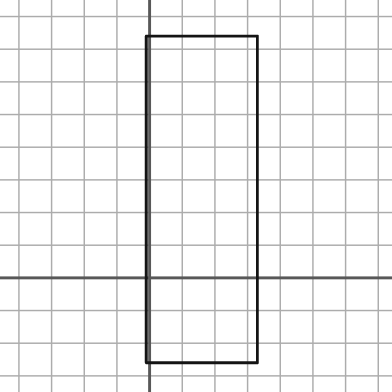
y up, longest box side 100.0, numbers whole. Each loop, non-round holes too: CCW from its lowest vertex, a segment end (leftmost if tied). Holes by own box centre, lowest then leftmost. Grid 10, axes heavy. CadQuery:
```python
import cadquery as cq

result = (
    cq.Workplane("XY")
    .moveTo(-1.0, -26.0)
    .lineTo(33.0, -26.0)
    .lineTo(33.0, 74.0)
    .lineTo(-1.0, 74.0)
    .close()
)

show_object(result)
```